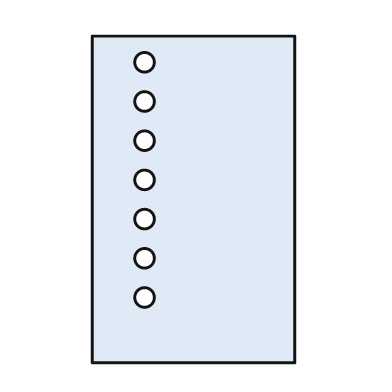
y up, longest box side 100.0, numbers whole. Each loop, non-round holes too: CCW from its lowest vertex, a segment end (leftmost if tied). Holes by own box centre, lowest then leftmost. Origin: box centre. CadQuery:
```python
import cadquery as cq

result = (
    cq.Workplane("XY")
    .moveTo(-31.0, -50.0)
    .lineTo(31.0, -50.0)
    .lineTo(31.0, 50.0)
    .lineTo(-31.0, 50.0)
    .close()
    .moveTo(-15.0, -30.0)
    .circle(3.0)
    .moveTo(-15.0, -18.0)
    .circle(3.0)
    .moveTo(-15.0, -6.0)
    .circle(3.0)
    .moveTo(-15.0, 6.0)
    .circle(3.0)
    .moveTo(-15.0, 18.0)
    .circle(3.0)
    .moveTo(-15.0, 30.0)
    .circle(3.0)
    .moveTo(-15.0, 42.0)
    .circle(3.0)
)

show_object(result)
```